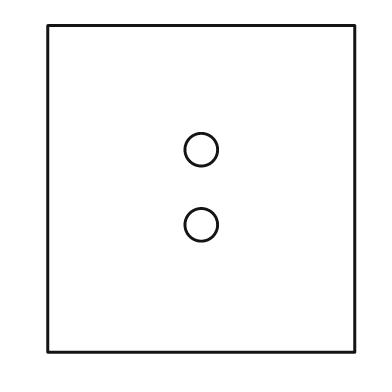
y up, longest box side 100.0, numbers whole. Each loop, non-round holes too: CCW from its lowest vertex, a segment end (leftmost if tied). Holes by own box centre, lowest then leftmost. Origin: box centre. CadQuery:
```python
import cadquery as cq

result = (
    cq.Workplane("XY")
    .moveTo(-47.0, -50.0)
    .lineTo(47.0, -50.0)
    .lineTo(47.0, 50.0)
    .lineTo(-47.0, 50.0)
    .close()
    .moveTo(0.0, -11.0)
    .circle(5.0)
    .moveTo(0.0, 12.0)
    .circle(5.0)
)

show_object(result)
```